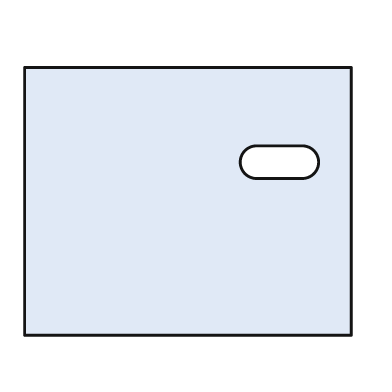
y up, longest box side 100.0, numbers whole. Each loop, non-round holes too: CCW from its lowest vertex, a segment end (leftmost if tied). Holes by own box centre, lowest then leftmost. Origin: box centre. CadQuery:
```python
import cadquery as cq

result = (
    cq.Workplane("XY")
    .moveTo(-50.0, -41.0)
    .lineTo(50.0, -41.0)
    .lineTo(50.0, 41.0)
    .lineTo(-50.0, 41.0)
    .close()
    .moveTo(21.0, 7.0)
    .lineTo(35.0, 7.0)
    .threePointArc((40.0, 12.0), (35.0, 17.0))
    .lineTo(21.0, 17.0)
    .threePointArc((16.0, 12.0), (21.0, 7.0))
    .close()
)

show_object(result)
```